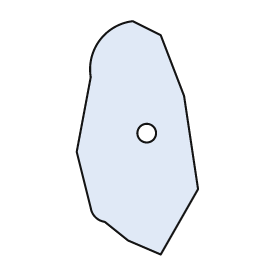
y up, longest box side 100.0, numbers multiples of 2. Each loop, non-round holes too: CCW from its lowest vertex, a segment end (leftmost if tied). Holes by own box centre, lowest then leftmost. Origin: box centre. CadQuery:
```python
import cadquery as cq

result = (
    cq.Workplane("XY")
    .moveTo(10.0, -50.0)
    .lineTo(26.0, -22.0)
    .lineTo(20.0, 18.0)
    .lineTo(10.0, 44.0)
    .lineTo(-2.0, 50.0)
    .threePointArc((-16.0, 42.0), (-20.0, 26.0))
    .lineTo(-26.0, -6.0)
    .lineTo(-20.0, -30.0)
    .threePointArc((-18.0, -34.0), (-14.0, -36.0))
    .lineTo(-4.0, -44.0)
    .close()
    .moveTo(4.0, 2.0)
    .circle(4.0)
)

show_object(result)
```